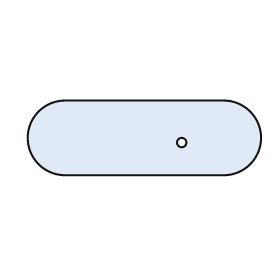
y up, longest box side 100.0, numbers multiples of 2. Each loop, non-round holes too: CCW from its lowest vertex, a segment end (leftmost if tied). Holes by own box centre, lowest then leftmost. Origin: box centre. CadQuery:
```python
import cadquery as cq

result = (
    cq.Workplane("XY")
    .moveTo(-34.0, -16.0)
    .lineTo(34.0, -16.0)
    .threePointArc((50.0, 0.0), (34.0, 16.0))
    .lineTo(-34.0, 16.0)
    .threePointArc((-50.0, 0.0), (-34.0, -16.0))
    .close()
    .moveTo(16.0, -2.0)
    .circle(2.0)
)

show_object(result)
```